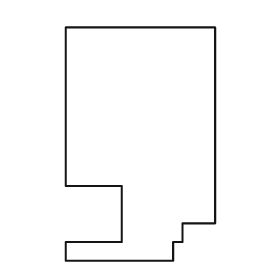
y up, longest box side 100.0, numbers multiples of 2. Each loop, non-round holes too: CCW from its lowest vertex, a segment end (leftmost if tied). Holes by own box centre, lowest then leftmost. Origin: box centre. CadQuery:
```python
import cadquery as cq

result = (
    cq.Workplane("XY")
    .moveTo(-32.0, -50.0)
    .lineTo(14.0, -50.0)
    .lineTo(14.0, -42.0)
    .lineTo(18.0, -42.0)
    .lineTo(18.0, -34.0)
    .lineTo(32.0, -34.0)
    .lineTo(32.0, 50.0)
    .lineTo(-32.0, 50.0)
    .lineTo(-32.0, -18.0)
    .lineTo(-8.0, -18.0)
    .lineTo(-8.0, -42.0)
    .lineTo(-32.0, -42.0)
    .close()
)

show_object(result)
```